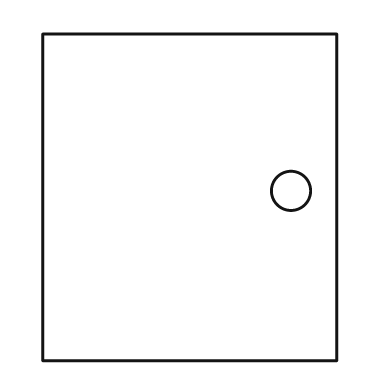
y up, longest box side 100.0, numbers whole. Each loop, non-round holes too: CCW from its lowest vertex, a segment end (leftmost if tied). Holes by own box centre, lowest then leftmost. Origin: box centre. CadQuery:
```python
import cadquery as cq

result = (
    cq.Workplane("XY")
    .moveTo(-45.0, -50.0)
    .lineTo(45.0, -50.0)
    .lineTo(45.0, 50.0)
    .lineTo(-45.0, 50.0)
    .close()
    .moveTo(31.0, 2.0)
    .circle(6.0)
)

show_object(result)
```